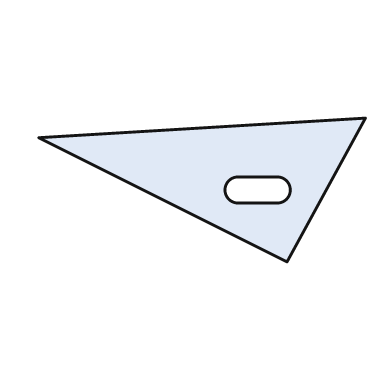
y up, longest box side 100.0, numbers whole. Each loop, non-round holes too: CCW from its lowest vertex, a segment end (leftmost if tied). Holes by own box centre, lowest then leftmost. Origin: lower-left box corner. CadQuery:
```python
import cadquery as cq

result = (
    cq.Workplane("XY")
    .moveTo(76.0, 0.0)
    .lineTo(100.0, 44.0)
    .lineTo(0.0, 38.0)
    .close()
    .moveTo(61.0, 18.0)
    .lineTo(73.0, 18.0)
    .threePointArc((77.0, 22.0), (73.0, 26.0))
    .lineTo(61.0, 26.0)
    .threePointArc((57.0, 22.0), (61.0, 18.0))
    .close()
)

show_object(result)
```